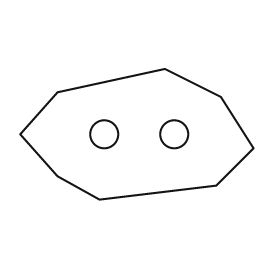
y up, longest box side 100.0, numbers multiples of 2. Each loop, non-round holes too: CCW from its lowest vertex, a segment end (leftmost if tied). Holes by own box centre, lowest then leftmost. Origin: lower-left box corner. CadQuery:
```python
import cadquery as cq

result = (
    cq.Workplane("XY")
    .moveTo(34.0, 0.0)
    .lineTo(84.0, 6.0)
    .lineTo(100.0, 22.0)
    .lineTo(86.0, 44.0)
    .lineTo(62.0, 56.0)
    .lineTo(16.0, 46.0)
    .lineTo(0.0, 28.0)
    .lineTo(16.0, 10.0)
    .close()
    .moveTo(36.0, 28.0)
    .circle(6.0)
    .moveTo(66.0, 28.0)
    .circle(6.0)
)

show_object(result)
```